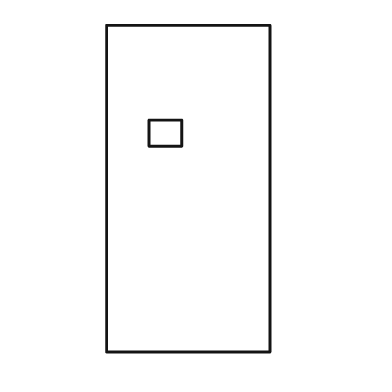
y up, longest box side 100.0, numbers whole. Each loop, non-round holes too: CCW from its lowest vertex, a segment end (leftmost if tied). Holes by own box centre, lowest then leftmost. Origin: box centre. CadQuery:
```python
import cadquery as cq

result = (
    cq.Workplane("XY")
    .moveTo(-25.0, -50.0)
    .lineTo(25.0, -50.0)
    .lineTo(25.0, 50.0)
    .lineTo(-25.0, 50.0)
    .close()
    .moveTo(-12.0, 13.0)
    .lineTo(-2.0, 13.0)
    .lineTo(-2.0, 21.0)
    .lineTo(-12.0, 21.0)
    .close()
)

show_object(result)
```